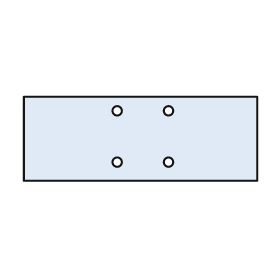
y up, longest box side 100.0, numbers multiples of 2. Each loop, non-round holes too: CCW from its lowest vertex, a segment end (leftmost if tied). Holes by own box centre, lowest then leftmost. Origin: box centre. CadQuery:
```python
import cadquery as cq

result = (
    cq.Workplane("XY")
    .moveTo(-50.0, -18.0)
    .lineTo(50.0, -18.0)
    .lineTo(50.0, 18.0)
    .lineTo(-50.0, 18.0)
    .close()
    .moveTo(-10.0, -10.0)
    .circle(2.0)
    .moveTo(12.0, -10.0)
    .circle(2.0)
    .moveTo(-10.0, 12.0)
    .circle(2.0)
    .moveTo(12.0, 12.0)
    .circle(2.0)
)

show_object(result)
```